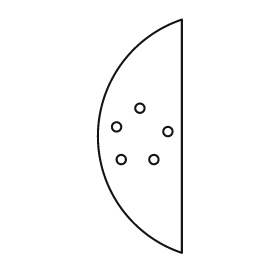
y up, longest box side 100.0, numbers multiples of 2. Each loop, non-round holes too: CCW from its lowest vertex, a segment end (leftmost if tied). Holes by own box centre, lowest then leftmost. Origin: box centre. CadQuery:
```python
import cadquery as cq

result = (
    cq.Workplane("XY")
    .moveTo(18.0, -50.0)
    .lineTo(18.0, 50.0)
    .threePointArc((-18.0, 0.0), (18.0, -50.0))
    .close()
    .moveTo(-8.0, -10.0)
    .circle(2.0)
    .moveTo(6.0, -10.0)
    .circle(2.0)
    .moveTo(12.0, 2.0)
    .circle(2.0)
    .moveTo(-10.0, 4.0)
    .circle(2.0)
    .moveTo(0.0, 12.0)
    .circle(2.0)
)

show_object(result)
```